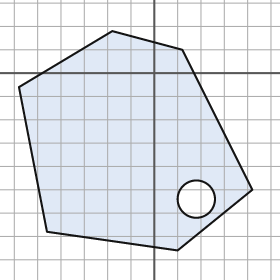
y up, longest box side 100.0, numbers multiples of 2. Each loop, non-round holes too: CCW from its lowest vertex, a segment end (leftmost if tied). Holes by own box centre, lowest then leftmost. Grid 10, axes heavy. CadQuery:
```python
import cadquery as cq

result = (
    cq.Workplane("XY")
    .moveTo(10.0, -76.0)
    .lineTo(42.0, -50.0)
    .lineTo(12.0, 10.0)
    .lineTo(-18.0, 18.0)
    .lineTo(-58.0, -6.0)
    .lineTo(-46.0, -68.0)
    .close()
    .moveTo(18.0, -54.0)
    .circle(8.0)
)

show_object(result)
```